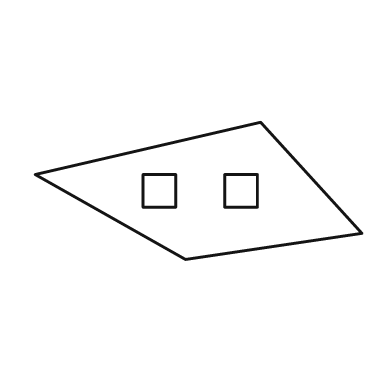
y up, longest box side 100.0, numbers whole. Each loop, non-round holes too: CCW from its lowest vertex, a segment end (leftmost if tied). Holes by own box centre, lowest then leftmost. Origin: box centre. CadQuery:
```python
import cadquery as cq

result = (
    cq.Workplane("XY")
    .moveTo(-4.0, -21.0)
    .lineTo(50.0, -13.0)
    .lineTo(19.0, 21.0)
    .lineTo(-50.0, 5.0)
    .close()
    .moveTo(-17.0, -5.0)
    .lineTo(-7.0, -5.0)
    .lineTo(-7.0, 5.0)
    .lineTo(-17.0, 5.0)
    .close()
    .moveTo(8.0, -5.0)
    .lineTo(18.0, -5.0)
    .lineTo(18.0, 5.0)
    .lineTo(8.0, 5.0)
    .close()
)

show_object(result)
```